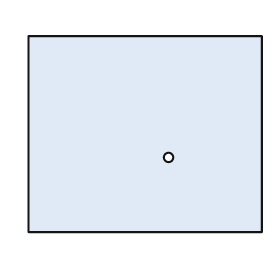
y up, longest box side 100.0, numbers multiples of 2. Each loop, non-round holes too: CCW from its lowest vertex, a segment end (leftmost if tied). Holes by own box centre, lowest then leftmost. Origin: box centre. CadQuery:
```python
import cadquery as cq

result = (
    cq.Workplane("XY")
    .moveTo(-50.0, -42.0)
    .lineTo(50.0, -42.0)
    .lineTo(50.0, 42.0)
    .lineTo(-50.0, 42.0)
    .close()
    .moveTo(10.0, -10.0)
    .circle(2.0)
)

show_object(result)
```